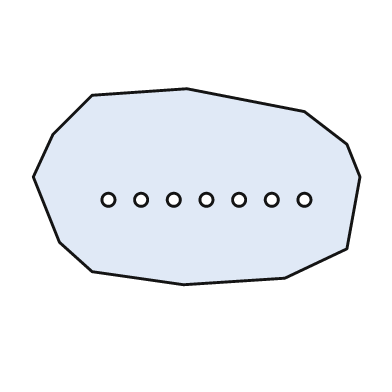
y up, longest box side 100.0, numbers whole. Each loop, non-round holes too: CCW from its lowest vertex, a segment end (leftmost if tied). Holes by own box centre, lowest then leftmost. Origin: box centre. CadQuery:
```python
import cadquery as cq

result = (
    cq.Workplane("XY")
    .moveTo(-4.0, -30.0)
    .lineTo(27.0, -28.0)
    .lineTo(46.0, -19.0)
    .lineTo(50.0, 3.0)
    .lineTo(46.0, 13.0)
    .lineTo(33.0, 23.0)
    .lineTo(-3.0, 30.0)
    .lineTo(-32.0, 28.0)
    .lineTo(-44.0, 16.0)
    .lineTo(-50.0, 3.0)
    .lineTo(-42.0, -17.0)
    .lineTo(-32.0, -26.0)
    .close()
    .moveTo(-27.0, -4.0)
    .circle(2.0)
    .moveTo(-17.0, -4.0)
    .circle(2.0)
    .moveTo(-7.0, -4.0)
    .circle(2.0)
    .moveTo(3.0, -4.0)
    .circle(2.0)
    .moveTo(13.0, -4.0)
    .circle(2.0)
    .moveTo(23.0, -4.0)
    .circle(2.0)
    .moveTo(33.0, -4.0)
    .circle(2.0)
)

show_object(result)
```